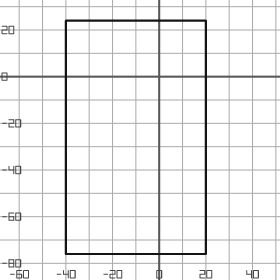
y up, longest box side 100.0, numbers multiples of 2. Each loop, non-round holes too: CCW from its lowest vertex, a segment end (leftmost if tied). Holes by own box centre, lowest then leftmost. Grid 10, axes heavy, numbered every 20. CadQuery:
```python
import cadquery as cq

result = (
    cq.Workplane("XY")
    .moveTo(-40.0, -76.0)
    .lineTo(20.0, -76.0)
    .lineTo(20.0, 24.0)
    .lineTo(-40.0, 24.0)
    .close()
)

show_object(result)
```